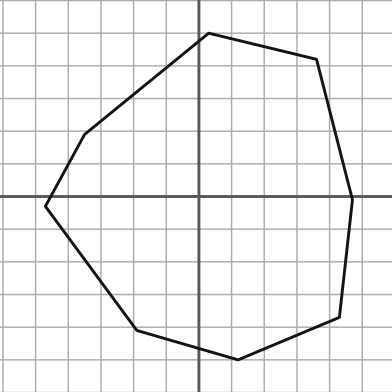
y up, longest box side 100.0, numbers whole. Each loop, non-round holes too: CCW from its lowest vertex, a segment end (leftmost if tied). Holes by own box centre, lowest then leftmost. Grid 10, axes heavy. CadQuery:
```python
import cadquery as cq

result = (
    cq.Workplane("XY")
    .moveTo(12.0, -50.0)
    .lineTo(43.0, -37.0)
    .lineTo(47.0, -1.0)
    .lineTo(36.0, 42.0)
    .lineTo(3.0, 50.0)
    .lineTo(-35.0, 19.0)
    .lineTo(-47.0, -3.0)
    .lineTo(-19.0, -41.0)
    .close()
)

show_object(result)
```